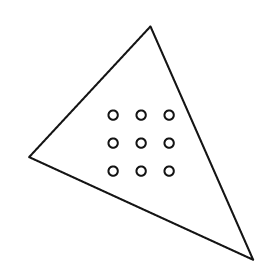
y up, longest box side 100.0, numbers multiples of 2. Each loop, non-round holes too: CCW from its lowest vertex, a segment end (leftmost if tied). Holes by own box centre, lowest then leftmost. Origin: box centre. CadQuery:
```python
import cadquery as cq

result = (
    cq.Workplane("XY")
    .moveTo(48.0, -50.0)
    .lineTo(4.0, 50.0)
    .lineTo(-48.0, -6.0)
    .close()
    .moveTo(-12.0, -12.0)
    .circle(2.0)
    .moveTo(0.0, -12.0)
    .circle(2.0)
    .moveTo(12.0, -12.0)
    .circle(2.0)
    .moveTo(-12.0, 0.0)
    .circle(2.0)
    .moveTo(0.0, 0.0)
    .circle(2.0)
    .moveTo(12.0, 0.0)
    .circle(2.0)
    .moveTo(-12.0, 12.0)
    .circle(2.0)
    .moveTo(0.0, 12.0)
    .circle(2.0)
    .moveTo(12.0, 12.0)
    .circle(2.0)
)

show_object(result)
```